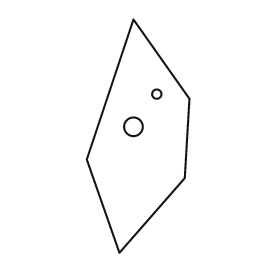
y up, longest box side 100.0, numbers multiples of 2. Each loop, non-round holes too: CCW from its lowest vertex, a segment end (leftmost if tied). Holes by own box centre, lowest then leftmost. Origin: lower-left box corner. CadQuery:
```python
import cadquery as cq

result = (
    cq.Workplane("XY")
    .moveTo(14.0, 0.0)
    .lineTo(42.0, 32.0)
    .lineTo(44.0, 66.0)
    .lineTo(20.0, 100.0)
    .lineTo(0.0, 40.0)
    .close()
    .moveTo(20.0, 54.0)
    .circle(4.0)
    .moveTo(30.0, 68.0)
    .circle(2.0)
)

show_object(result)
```